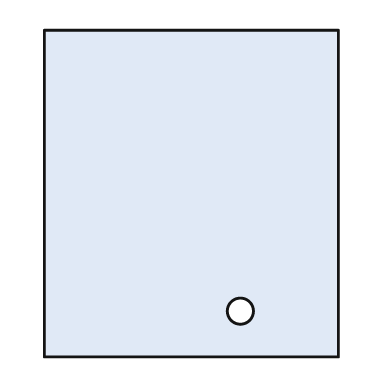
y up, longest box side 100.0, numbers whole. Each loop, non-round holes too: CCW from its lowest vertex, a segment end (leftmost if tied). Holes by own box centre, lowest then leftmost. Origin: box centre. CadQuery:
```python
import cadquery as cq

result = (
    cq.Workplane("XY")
    .moveTo(-45.0, -50.0)
    .lineTo(45.0, -50.0)
    .lineTo(45.0, 50.0)
    .lineTo(-45.0, 50.0)
    .close()
    .moveTo(15.0, -36.0)
    .circle(4.0)
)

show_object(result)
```